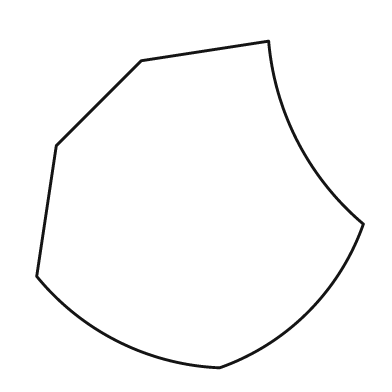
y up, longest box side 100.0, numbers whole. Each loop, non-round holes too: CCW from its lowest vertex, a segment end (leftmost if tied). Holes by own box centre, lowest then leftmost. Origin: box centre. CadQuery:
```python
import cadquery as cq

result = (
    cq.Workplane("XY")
    .moveTo(6.0, -50.0)
    .threePointArc((33.0, -33.0), (50.0, -6.0))
    .threePointArc((30.0, 19.0), (21.0, 50.0))
    .lineTo(-18.0, 44.0)
    .lineTo(-44.0, 18.0)
    .lineTo(-50.0, -22.0)
    .threePointArc((-25.0, -42.0), (6.0, -50.0))
    .close()
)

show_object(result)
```